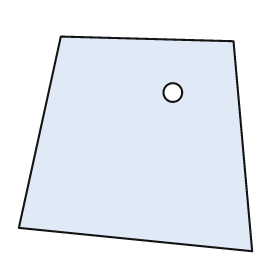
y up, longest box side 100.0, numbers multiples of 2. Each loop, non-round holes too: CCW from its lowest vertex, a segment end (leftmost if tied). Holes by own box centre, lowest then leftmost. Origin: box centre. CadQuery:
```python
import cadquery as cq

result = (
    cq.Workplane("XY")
    .moveTo(50.0, -46.0)
    .lineTo(42.0, 44.0)
    .lineTo(-32.0, 46.0)
    .lineTo(-50.0, -36.0)
    .close()
    .moveTo(16.0, 22.0)
    .circle(4.0)
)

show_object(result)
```